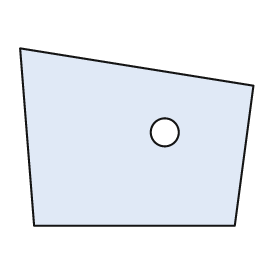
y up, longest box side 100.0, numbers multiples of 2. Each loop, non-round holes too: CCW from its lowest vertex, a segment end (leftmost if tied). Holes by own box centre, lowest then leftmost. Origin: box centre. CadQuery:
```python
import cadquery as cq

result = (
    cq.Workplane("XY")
    .moveTo(-44.0, -38.0)
    .lineTo(42.0, -38.0)
    .lineTo(50.0, 22.0)
    .lineTo(-50.0, 38.0)
    .close()
    .moveTo(12.0, 2.0)
    .circle(6.0)
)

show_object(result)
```